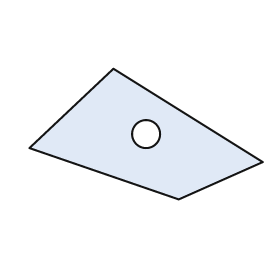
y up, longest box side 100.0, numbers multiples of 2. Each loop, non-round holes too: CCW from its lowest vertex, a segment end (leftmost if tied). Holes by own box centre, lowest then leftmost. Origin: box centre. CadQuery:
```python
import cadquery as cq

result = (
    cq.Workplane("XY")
    .moveTo(14.0, -28.0)
    .lineTo(50.0, -12.0)
    .lineTo(-14.0, 28.0)
    .lineTo(-50.0, -6.0)
    .close()
    .moveTo(0.0, 0.0)
    .circle(6.0)
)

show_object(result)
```